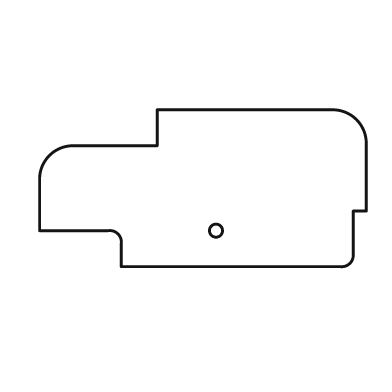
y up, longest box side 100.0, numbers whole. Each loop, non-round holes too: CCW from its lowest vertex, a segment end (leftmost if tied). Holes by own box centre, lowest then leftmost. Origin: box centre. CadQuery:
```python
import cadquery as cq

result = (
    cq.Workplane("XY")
    .moveTo(-25.0, -24.0)
    .lineTo(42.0, -24.0)
    .threePointArc((45.0, -23.0), (46.0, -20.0))
    .lineTo(46.0, -7.0)
    .lineTo(50.0, -7.0)
    .lineTo(50.0, 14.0)
    .threePointArc((47.0, 21.0), (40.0, 24.0))
    .lineTo(-14.0, 24.0)
    .lineTo(-14.0, 13.0)
    .lineTo(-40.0, 13.0)
    .threePointArc((-47.0, 10.0), (-50.0, 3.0))
    .lineTo(-50.0, -13.0)
    .lineTo(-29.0, -13.0)
    .threePointArc((-26.0, -14.0), (-25.0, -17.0))
    .close()
    .moveTo(4.0, -13.0)
    .circle(2.0)
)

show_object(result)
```